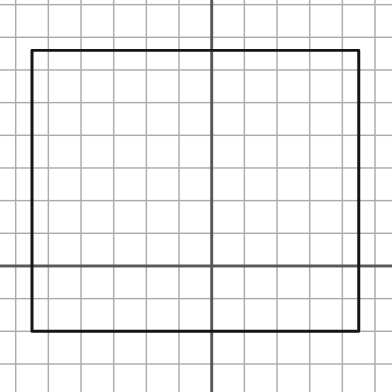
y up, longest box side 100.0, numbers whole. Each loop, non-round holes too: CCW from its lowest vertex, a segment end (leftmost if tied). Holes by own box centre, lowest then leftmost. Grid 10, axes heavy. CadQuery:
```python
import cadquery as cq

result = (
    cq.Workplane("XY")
    .moveTo(-55.0, -20.0)
    .lineTo(45.0, -20.0)
    .lineTo(45.0, 66.0)
    .lineTo(-55.0, 66.0)
    .close()
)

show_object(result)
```